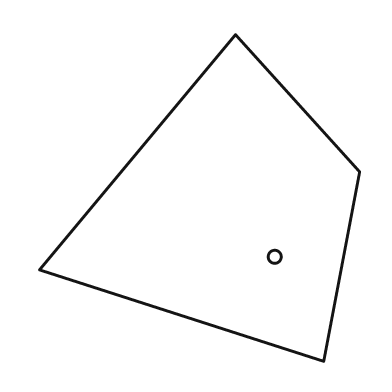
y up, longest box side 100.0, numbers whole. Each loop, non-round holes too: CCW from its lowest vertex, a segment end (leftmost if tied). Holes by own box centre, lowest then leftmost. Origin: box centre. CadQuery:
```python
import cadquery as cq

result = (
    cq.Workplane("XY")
    .moveTo(38.0, -50.0)
    .lineTo(49.0, 8.0)
    .lineTo(11.0, 50.0)
    .lineTo(-49.0, -22.0)
    .close()
    .moveTo(23.0, -18.0)
    .circle(2.0)
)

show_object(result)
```